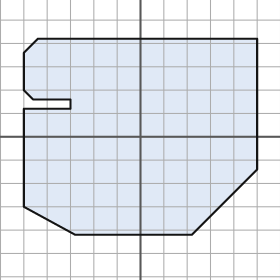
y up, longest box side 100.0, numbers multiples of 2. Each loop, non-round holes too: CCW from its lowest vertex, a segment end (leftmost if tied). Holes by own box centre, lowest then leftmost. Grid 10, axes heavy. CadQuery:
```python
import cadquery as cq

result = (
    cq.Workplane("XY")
    .moveTo(-28.0, -42.0)
    .lineTo(22.0, -42.0)
    .lineTo(50.0, -14.0)
    .lineTo(50.0, 42.0)
    .lineTo(-44.0, 42.0)
    .lineTo(-50.0, 36.0)
    .lineTo(-50.0, 20.0)
    .lineTo(-46.0, 16.0)
    .lineTo(-30.0, 16.0)
    .lineTo(-30.0, 12.0)
    .lineTo(-50.0, 12.0)
    .lineTo(-50.0, -30.0)
    .close()
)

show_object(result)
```